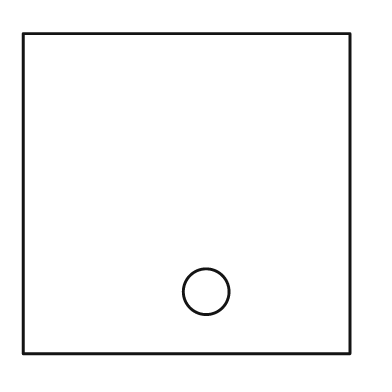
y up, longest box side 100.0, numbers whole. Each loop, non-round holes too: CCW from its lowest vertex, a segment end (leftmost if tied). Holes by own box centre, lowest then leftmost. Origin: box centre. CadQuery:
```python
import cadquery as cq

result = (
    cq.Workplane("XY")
    .moveTo(-50.0, -49.0)
    .lineTo(50.0, -49.0)
    .lineTo(50.0, 49.0)
    .lineTo(-50.0, 49.0)
    .close()
    .moveTo(6.0, -30.0)
    .circle(7.0)
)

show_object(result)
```